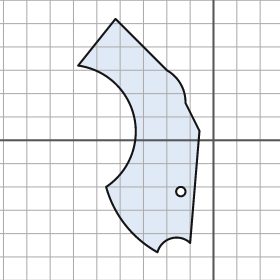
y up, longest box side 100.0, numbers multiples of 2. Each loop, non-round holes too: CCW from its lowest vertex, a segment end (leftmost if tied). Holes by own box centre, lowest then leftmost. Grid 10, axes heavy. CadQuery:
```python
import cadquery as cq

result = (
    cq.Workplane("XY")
    .moveTo(-24.0, -48.0)
    .threePointArc((-18.0, -42.0), (-10.0, -44.0))
    .lineTo(-6.0, 4.0)
    .lineTo(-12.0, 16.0)
    .threePointArc((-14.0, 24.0), (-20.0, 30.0))
    .lineTo(-42.0, 52.0)
    .lineTo(-58.0, 32.0)
    .threePointArc((-34.0, 10.0), (-46.0, -20.0))
    .threePointArc((-38.0, -36.0), (-24.0, -48.0))
    .close()
    .moveTo(-14.0, -22.0)
    .circle(2.0)
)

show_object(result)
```